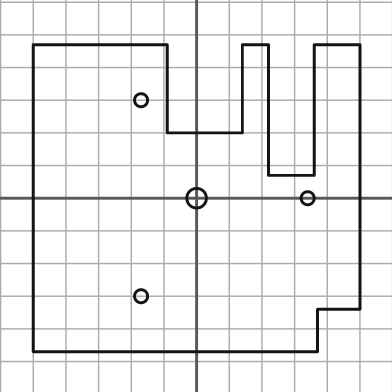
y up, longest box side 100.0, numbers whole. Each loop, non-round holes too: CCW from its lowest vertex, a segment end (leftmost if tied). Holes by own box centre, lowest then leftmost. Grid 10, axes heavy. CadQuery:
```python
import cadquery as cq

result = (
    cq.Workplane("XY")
    .moveTo(-50.0, -47.0)
    .lineTo(37.0, -47.0)
    .lineTo(37.0, -34.0)
    .lineTo(50.0, -34.0)
    .lineTo(50.0, 47.0)
    .lineTo(36.0, 47.0)
    .lineTo(36.0, 7.0)
    .lineTo(22.0, 7.0)
    .lineTo(22.0, 47.0)
    .lineTo(14.0, 47.0)
    .lineTo(14.0, 20.0)
    .lineTo(-9.0, 20.0)
    .lineTo(-9.0, 47.0)
    .lineTo(-50.0, 47.0)
    .close()
    .moveTo(-17.0, -30.0)
    .circle(2.0)
    .moveTo(0.0, 0.0)
    .circle(3.0)
    .moveTo(34.0, 0.0)
    .circle(2.0)
    .moveTo(-17.0, 30.0)
    .circle(2.0)
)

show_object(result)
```